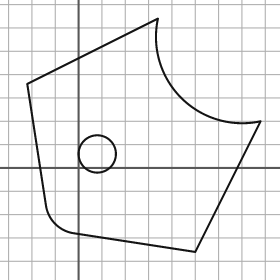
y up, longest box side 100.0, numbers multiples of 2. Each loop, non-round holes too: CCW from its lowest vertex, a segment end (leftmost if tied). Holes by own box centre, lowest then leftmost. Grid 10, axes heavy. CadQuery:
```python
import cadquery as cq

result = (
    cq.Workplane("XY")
    .moveTo(50.0, -36.0)
    .lineTo(78.0, 20.0)
    .threePointArc((44.0, 30.0), (34.0, 64.0))
    .lineTo(-22.0, 36.0)
    .lineTo(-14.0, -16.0)
    .threePointArc((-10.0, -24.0), (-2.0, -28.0))
    .close()
    .moveTo(8.0, 6.0)
    .circle(8.0)
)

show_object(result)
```